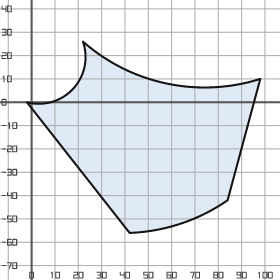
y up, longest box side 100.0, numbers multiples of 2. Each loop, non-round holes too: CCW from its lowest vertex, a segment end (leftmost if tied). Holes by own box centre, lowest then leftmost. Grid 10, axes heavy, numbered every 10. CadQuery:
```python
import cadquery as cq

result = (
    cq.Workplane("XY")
    .moveTo(42.0, -56.0)
    .threePointArc((64.0, -52.0), (84.0, -42.0))
    .lineTo(98.0, 10.0)
    .threePointArc((58.0, 8.0), (22.0, 26.0))
    .threePointArc((18.0, 6.0), (-2.0, 0.0))
    .close()
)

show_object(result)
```